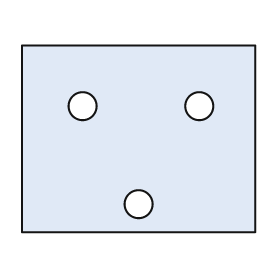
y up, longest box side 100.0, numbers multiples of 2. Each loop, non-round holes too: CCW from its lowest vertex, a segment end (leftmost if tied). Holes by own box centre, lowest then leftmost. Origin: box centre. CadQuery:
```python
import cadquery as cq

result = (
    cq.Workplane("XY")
    .moveTo(-50.0, -40.0)
    .lineTo(50.0, -40.0)
    .lineTo(50.0, 40.0)
    .lineTo(-50.0, 40.0)
    .close()
    .moveTo(0.0, -28.0)
    .circle(6.0)
    .moveTo(-24.0, 14.0)
    .circle(6.0)
    .moveTo(26.0, 14.0)
    .circle(6.0)
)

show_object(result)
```